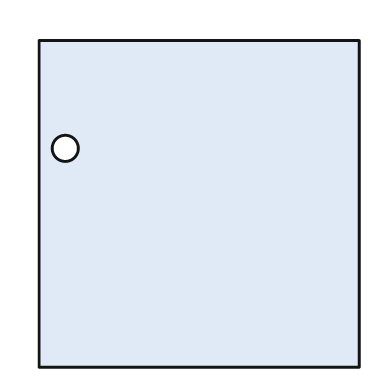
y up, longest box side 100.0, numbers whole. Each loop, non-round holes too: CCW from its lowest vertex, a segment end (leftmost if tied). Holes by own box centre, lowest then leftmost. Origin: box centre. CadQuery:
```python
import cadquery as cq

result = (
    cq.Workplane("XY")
    .moveTo(-49.0, -50.0)
    .lineTo(49.0, -50.0)
    .lineTo(49.0, 50.0)
    .lineTo(-49.0, 50.0)
    .close()
    .moveTo(-41.0, 17.0)
    .circle(4.0)
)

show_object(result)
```